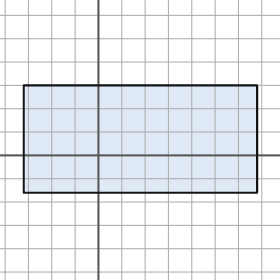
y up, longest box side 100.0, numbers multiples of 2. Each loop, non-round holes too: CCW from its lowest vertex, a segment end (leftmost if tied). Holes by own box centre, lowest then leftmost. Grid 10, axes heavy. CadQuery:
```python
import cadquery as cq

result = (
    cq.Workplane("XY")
    .moveTo(-32.0, -16.0)
    .lineTo(68.0, -16.0)
    .lineTo(68.0, 30.0)
    .lineTo(-32.0, 30.0)
    .close()
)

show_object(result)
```